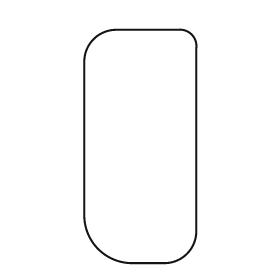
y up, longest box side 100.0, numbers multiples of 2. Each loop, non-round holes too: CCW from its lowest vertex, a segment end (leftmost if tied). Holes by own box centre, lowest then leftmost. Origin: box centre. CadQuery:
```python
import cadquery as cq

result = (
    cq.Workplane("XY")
    .moveTo(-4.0, -50.0)
    .lineTo(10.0, -50.0)
    .threePointArc((20.0, -46.0), (24.0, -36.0))
    .lineTo(24.0, 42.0)
    .threePointArc((22.0, 48.0), (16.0, 50.0))
    .lineTo(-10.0, 50.0)
    .threePointArc((-20.0, 46.0), (-24.0, 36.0))
    .lineTo(-24.0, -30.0)
    .threePointArc((-18.0, -44.0), (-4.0, -50.0))
    .close()
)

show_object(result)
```